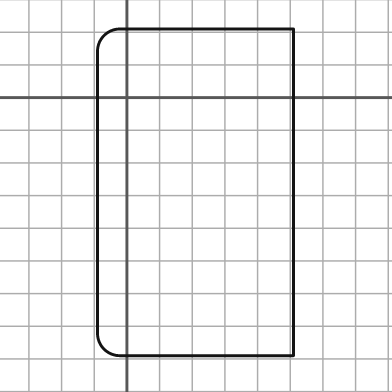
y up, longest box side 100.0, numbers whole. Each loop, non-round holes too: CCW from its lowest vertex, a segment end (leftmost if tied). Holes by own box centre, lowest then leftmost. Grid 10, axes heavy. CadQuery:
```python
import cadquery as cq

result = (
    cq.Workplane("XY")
    .moveTo(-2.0, -79.0)
    .lineTo(51.0, -79.0)
    .lineTo(51.0, 21.0)
    .lineTo(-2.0, 21.0)
    .threePointArc((-7.0, 19.0), (-9.0, 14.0))
    .lineTo(-9.0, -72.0)
    .threePointArc((-7.0, -77.0), (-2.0, -79.0))
    .close()
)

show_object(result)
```